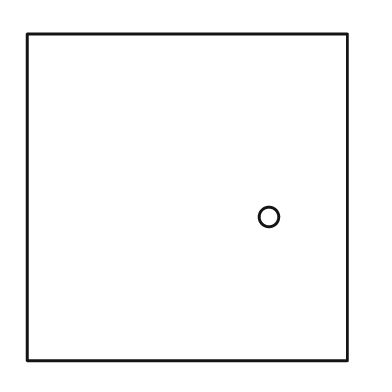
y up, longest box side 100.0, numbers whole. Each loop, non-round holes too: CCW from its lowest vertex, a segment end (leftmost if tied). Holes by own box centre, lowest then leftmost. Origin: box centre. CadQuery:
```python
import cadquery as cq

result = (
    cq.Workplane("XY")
    .moveTo(-49.0, -50.0)
    .lineTo(49.0, -50.0)
    .lineTo(49.0, 50.0)
    .lineTo(-49.0, 50.0)
    .close()
    .moveTo(25.0, -6.0)
    .circle(3.0)
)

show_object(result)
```